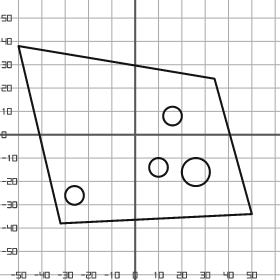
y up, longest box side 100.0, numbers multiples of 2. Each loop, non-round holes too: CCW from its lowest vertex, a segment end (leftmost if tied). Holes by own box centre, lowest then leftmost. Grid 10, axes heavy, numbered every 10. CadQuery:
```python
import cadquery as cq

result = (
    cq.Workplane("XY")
    .moveTo(-32.0, -38.0)
    .lineTo(50.0, -34.0)
    .lineTo(34.0, 24.0)
    .lineTo(-50.0, 38.0)
    .close()
    .moveTo(-26.0, -26.0)
    .circle(4.0)
    .moveTo(26.0, -16.0)
    .circle(6.0)
    .moveTo(10.0, -14.0)
    .circle(4.0)
    .moveTo(16.0, 8.0)
    .circle(4.0)
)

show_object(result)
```